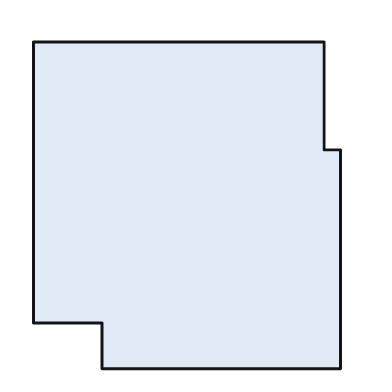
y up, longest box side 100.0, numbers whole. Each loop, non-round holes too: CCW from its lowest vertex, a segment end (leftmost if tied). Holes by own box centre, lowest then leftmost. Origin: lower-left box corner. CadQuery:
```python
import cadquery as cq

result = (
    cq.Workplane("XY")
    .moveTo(21.0, 0.0)
    .lineTo(94.0, 0.0)
    .lineTo(94.0, 67.0)
    .lineTo(89.0, 67.0)
    .lineTo(89.0, 100.0)
    .lineTo(0.0, 100.0)
    .lineTo(0.0, 14.0)
    .lineTo(21.0, 14.0)
    .close()
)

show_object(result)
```